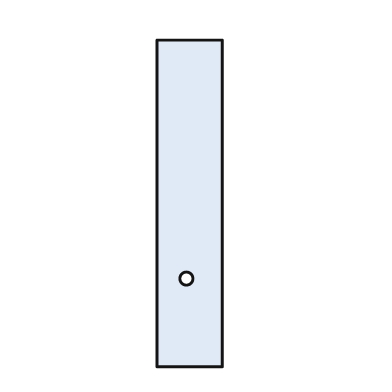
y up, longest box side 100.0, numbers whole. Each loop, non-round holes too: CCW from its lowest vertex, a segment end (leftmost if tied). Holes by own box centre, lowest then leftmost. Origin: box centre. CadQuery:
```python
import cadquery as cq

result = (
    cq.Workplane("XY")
    .moveTo(-10.0, -50.0)
    .lineTo(10.0, -50.0)
    .lineTo(10.0, 50.0)
    .lineTo(-10.0, 50.0)
    .close()
    .moveTo(-1.0, -23.0)
    .circle(2.0)
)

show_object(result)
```